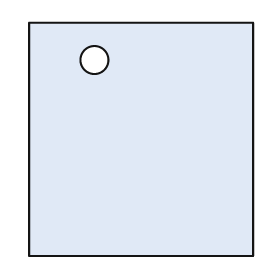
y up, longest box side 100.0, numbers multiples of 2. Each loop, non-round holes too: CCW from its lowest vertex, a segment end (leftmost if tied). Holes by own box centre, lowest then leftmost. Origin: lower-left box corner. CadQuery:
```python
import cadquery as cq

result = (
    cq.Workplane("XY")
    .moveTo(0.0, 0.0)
    .lineTo(96.0, 0.0)
    .lineTo(96.0, 100.0)
    .lineTo(0.0, 100.0)
    .close()
    .moveTo(28.0, 84.0)
    .circle(6.0)
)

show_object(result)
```